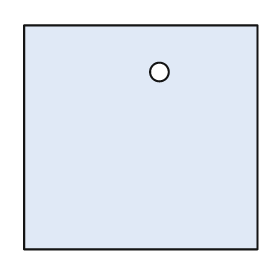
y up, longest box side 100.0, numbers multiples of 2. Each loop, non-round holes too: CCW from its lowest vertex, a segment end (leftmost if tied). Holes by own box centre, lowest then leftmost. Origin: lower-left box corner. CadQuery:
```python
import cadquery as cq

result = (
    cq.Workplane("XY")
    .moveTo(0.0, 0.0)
    .lineTo(100.0, 0.0)
    .lineTo(100.0, 96.0)
    .lineTo(0.0, 96.0)
    .close()
    .moveTo(58.0, 76.0)
    .circle(4.0)
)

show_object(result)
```